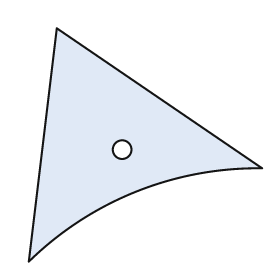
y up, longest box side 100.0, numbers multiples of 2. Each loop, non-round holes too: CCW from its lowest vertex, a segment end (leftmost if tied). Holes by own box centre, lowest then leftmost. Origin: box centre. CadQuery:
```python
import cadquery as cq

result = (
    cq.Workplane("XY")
    .moveTo(-50.0, -50.0)
    .threePointArc((-4.0, -20.0), (50.0, -10.0))
    .lineTo(-38.0, 50.0)
    .close()
    .moveTo(-10.0, -2.0)
    .circle(4.0)
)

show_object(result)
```